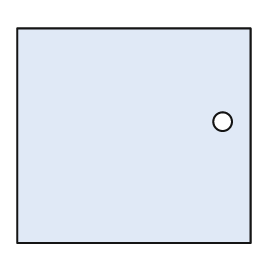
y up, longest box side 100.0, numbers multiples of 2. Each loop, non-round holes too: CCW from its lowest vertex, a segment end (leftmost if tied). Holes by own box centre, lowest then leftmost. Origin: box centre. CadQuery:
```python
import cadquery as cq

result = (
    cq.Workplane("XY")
    .moveTo(-50.0, -46.0)
    .lineTo(50.0, -46.0)
    .lineTo(50.0, 46.0)
    .lineTo(-50.0, 46.0)
    .close()
    .moveTo(38.0, 6.0)
    .circle(4.0)
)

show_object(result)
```